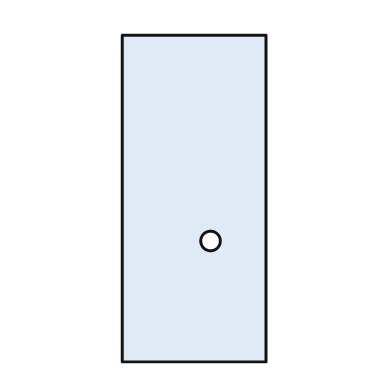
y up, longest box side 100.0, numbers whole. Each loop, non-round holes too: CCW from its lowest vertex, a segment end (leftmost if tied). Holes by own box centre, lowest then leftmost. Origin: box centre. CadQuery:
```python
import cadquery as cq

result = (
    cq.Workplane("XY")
    .moveTo(-22.0, -50.0)
    .lineTo(22.0, -50.0)
    .lineTo(22.0, 50.0)
    .lineTo(-22.0, 50.0)
    .close()
    .moveTo(5.0, -13.0)
    .circle(3.0)
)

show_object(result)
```